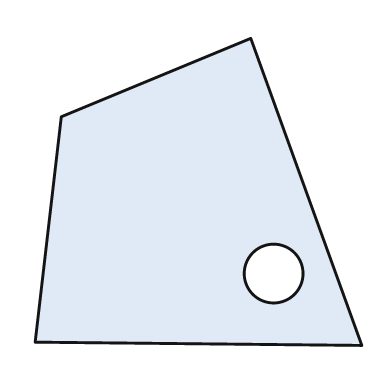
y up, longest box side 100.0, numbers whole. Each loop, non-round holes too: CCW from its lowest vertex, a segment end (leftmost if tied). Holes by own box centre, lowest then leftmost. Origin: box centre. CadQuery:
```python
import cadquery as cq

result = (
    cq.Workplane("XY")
    .moveTo(50.0, -47.0)
    .lineTo(16.0, 47.0)
    .lineTo(-42.0, 23.0)
    .lineTo(-50.0, -46.0)
    .close()
    .moveTo(23.0, -25.0)
    .circle(9.0)
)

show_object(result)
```